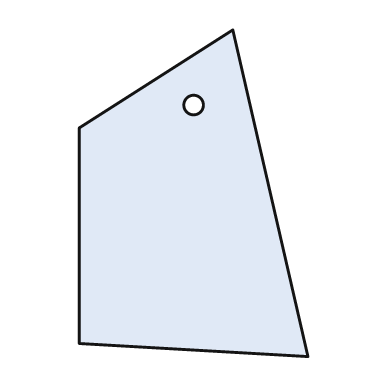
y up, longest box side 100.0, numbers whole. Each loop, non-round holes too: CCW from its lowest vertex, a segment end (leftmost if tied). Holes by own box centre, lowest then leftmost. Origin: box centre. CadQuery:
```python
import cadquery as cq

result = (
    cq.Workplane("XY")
    .moveTo(35.0, -50.0)
    .lineTo(12.0, 50.0)
    .lineTo(-35.0, 20.0)
    .lineTo(-35.0, -46.0)
    .close()
    .moveTo(0.0, 27.0)
    .circle(3.0)
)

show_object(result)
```